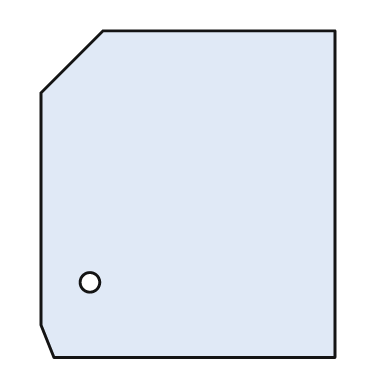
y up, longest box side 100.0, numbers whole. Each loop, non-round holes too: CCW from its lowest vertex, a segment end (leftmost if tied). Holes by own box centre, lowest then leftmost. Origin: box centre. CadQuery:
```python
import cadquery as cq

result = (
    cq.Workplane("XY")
    .moveTo(-41.0, -50.0)
    .lineTo(45.0, -50.0)
    .lineTo(45.0, 50.0)
    .lineTo(-26.0, 50.0)
    .lineTo(-45.0, 31.0)
    .lineTo(-45.0, -40.0)
    .close()
    .moveTo(-30.0, -27.0)
    .circle(3.0)
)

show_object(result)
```